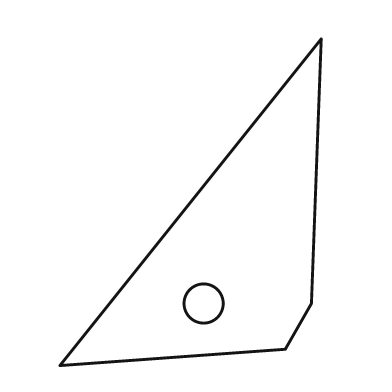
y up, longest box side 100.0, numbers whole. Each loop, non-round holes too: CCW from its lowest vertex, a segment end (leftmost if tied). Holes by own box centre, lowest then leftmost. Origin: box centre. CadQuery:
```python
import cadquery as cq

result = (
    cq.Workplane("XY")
    .moveTo(-40.0, -50.0)
    .lineTo(29.0, -45.0)
    .lineTo(37.0, -31.0)
    .lineTo(40.0, 50.0)
    .close()
    .moveTo(4.0, -31.0)
    .circle(6.0)
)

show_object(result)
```